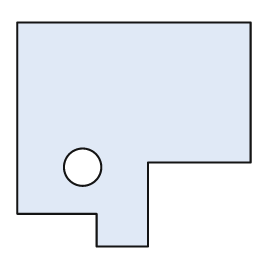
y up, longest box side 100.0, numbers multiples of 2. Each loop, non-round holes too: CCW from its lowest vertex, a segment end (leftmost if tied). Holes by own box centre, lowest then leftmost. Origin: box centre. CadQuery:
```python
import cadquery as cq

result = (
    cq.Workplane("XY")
    .moveTo(-16.0, -48.0)
    .lineTo(6.0, -48.0)
    .lineTo(6.0, -12.0)
    .lineTo(50.0, -12.0)
    .lineTo(50.0, 48.0)
    .lineTo(-50.0, 48.0)
    .lineTo(-50.0, -34.0)
    .lineTo(-16.0, -34.0)
    .close()
    .moveTo(-22.0, -14.0)
    .circle(8.0)
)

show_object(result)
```